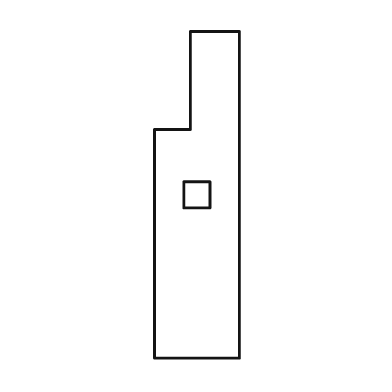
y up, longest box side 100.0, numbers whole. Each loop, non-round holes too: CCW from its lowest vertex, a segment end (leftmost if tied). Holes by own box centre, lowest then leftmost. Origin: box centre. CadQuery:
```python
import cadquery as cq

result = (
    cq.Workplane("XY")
    .moveTo(-13.0, -50.0)
    .lineTo(13.0, -50.0)
    .lineTo(13.0, 50.0)
    .lineTo(-2.0, 50.0)
    .lineTo(-2.0, 20.0)
    .lineTo(-13.0, 20.0)
    .close()
    .moveTo(-4.0, -4.0)
    .lineTo(4.0, -4.0)
    .lineTo(4.0, 4.0)
    .lineTo(-4.0, 4.0)
    .close()
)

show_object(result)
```